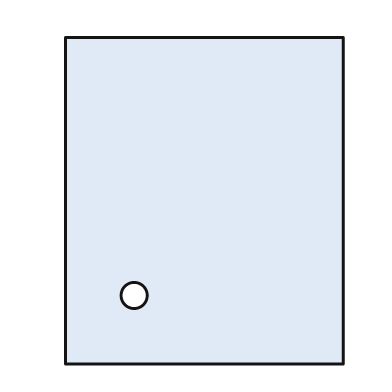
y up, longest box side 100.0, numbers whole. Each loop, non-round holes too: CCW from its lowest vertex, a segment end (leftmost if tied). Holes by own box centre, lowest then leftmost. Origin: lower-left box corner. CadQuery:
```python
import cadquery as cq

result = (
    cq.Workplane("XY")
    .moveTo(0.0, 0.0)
    .lineTo(85.0, 0.0)
    .lineTo(85.0, 100.0)
    .lineTo(0.0, 100.0)
    .close()
    .moveTo(21.0, 21.0)
    .circle(4.0)
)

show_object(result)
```